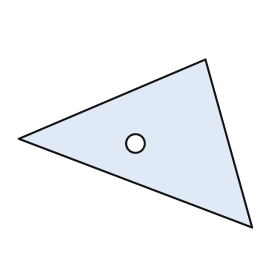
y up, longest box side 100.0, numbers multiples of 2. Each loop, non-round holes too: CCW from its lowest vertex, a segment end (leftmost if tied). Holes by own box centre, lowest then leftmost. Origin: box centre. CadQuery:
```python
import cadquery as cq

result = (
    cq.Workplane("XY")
    .moveTo(50.0, -36.0)
    .lineTo(30.0, 36.0)
    .lineTo(-50.0, 2.0)
    .close()
    .moveTo(0.0, 0.0)
    .circle(4.0)
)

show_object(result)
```